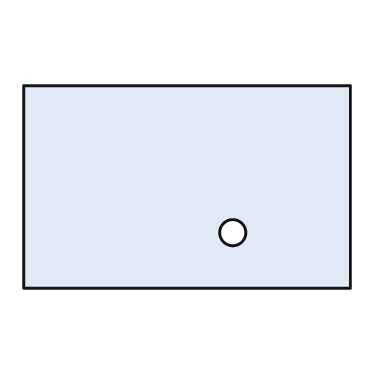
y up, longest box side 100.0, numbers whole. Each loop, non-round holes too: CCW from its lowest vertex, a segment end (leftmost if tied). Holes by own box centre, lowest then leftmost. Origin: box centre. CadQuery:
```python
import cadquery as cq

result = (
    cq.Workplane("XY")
    .moveTo(-50.0, -31.0)
    .lineTo(50.0, -31.0)
    .lineTo(50.0, 31.0)
    .lineTo(-50.0, 31.0)
    .close()
    .moveTo(14.0, -14.0)
    .circle(4.0)
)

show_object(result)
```